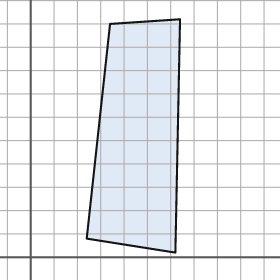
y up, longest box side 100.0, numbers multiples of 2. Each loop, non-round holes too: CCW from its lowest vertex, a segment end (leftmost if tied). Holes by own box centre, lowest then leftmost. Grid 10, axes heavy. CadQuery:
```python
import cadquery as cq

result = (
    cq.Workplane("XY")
    .moveTo(62.0, 2.0)
    .lineTo(64.0, 102.0)
    .lineTo(34.0, 100.0)
    .lineTo(24.0, 8.0)
    .close()
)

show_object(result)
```